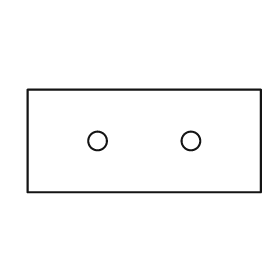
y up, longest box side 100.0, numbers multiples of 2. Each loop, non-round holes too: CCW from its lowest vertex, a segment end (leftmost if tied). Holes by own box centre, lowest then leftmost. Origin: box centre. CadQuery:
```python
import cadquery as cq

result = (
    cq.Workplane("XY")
    .moveTo(-50.0, -22.0)
    .lineTo(50.0, -22.0)
    .lineTo(50.0, 22.0)
    .lineTo(-50.0, 22.0)
    .close()
    .moveTo(-20.0, 0.0)
    .circle(4.0)
    .moveTo(20.0, 0.0)
    .circle(4.0)
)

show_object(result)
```